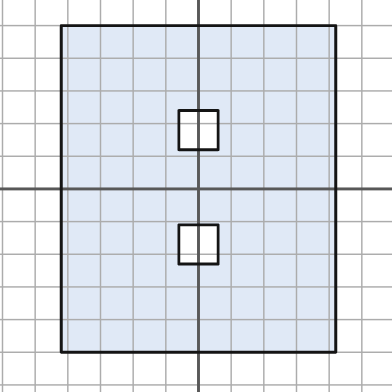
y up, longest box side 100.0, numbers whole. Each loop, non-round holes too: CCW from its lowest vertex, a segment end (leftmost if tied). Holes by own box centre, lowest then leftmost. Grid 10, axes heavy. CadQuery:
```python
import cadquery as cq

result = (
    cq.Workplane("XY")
    .moveTo(-42.0, -50.0)
    .lineTo(42.0, -50.0)
    .lineTo(42.0, 50.0)
    .lineTo(-42.0, 50.0)
    .close()
    .moveTo(-6.0, -23.0)
    .lineTo(6.0, -23.0)
    .lineTo(6.0, -11.0)
    .lineTo(-6.0, -11.0)
    .close()
    .moveTo(-6.0, 12.0)
    .lineTo(6.0, 12.0)
    .lineTo(6.0, 24.0)
    .lineTo(-6.0, 24.0)
    .close()
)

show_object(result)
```